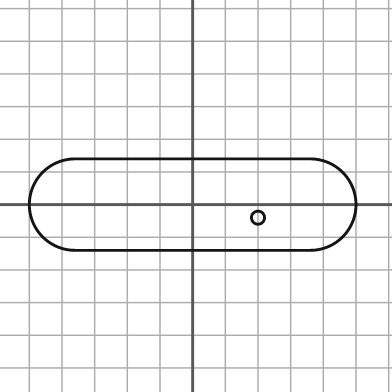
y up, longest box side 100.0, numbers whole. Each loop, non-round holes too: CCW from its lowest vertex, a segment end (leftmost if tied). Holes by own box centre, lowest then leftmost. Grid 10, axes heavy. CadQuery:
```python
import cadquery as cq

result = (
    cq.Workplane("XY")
    .moveTo(-36.0, -14.0)
    .lineTo(36.0, -14.0)
    .threePointArc((50.0, 0.0), (36.0, 14.0))
    .lineTo(-36.0, 14.0)
    .threePointArc((-50.0, 0.0), (-36.0, -14.0))
    .close()
    .moveTo(20.0, -4.0)
    .circle(2.0)
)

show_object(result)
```